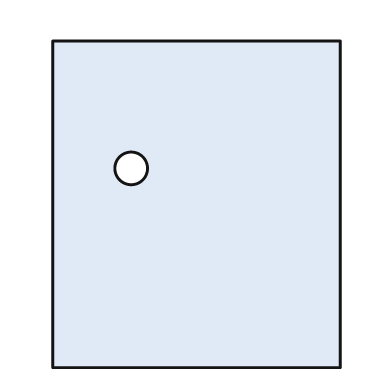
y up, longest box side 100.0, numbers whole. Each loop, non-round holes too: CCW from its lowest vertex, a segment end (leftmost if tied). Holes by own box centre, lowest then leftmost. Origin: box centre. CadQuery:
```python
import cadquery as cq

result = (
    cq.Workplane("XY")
    .moveTo(-44.0, -50.0)
    .lineTo(44.0, -50.0)
    .lineTo(44.0, 50.0)
    .lineTo(-44.0, 50.0)
    .close()
    .moveTo(-20.0, 11.0)
    .circle(5.0)
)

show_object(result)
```